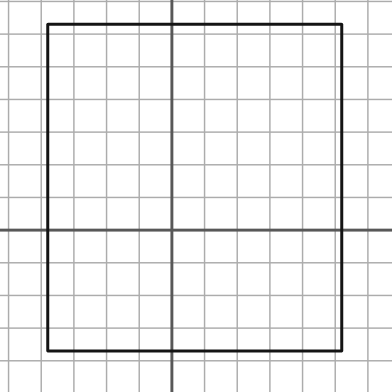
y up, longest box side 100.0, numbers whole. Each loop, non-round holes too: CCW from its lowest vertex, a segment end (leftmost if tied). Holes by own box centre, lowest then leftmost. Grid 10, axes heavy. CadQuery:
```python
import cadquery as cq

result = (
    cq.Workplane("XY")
    .moveTo(-38.0, -37.0)
    .lineTo(52.0, -37.0)
    .lineTo(52.0, 63.0)
    .lineTo(-38.0, 63.0)
    .close()
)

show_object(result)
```